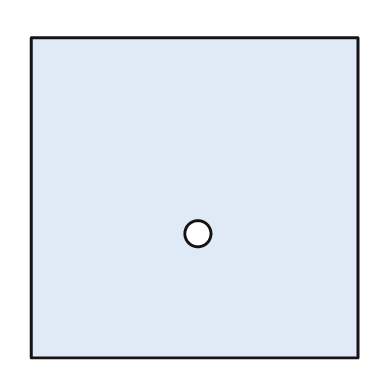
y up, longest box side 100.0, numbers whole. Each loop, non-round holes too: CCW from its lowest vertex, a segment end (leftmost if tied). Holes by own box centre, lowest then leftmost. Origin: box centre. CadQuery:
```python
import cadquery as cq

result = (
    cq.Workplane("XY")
    .moveTo(-50.0, -49.0)
    .lineTo(50.0, -49.0)
    .lineTo(50.0, 49.0)
    .lineTo(-50.0, 49.0)
    .close()
    .moveTo(1.0, -11.0)
    .circle(4.0)
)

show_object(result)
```